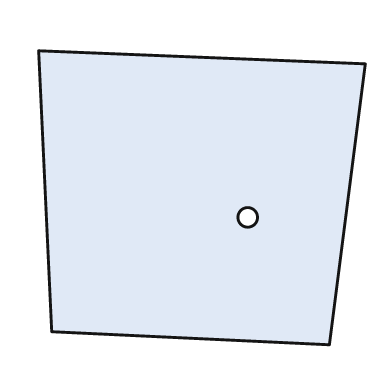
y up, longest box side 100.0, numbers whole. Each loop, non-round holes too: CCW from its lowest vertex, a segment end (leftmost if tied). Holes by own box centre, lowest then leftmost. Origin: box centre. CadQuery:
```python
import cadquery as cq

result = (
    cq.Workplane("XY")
    .moveTo(39.0, -45.0)
    .lineTo(50.0, 41.0)
    .lineTo(-50.0, 45.0)
    .lineTo(-46.0, -41.0)
    .close()
    .moveTo(14.0, -6.0)
    .circle(3.0)
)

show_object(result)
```